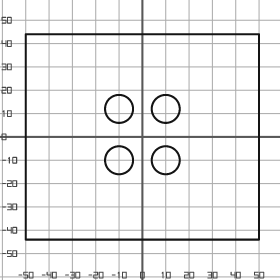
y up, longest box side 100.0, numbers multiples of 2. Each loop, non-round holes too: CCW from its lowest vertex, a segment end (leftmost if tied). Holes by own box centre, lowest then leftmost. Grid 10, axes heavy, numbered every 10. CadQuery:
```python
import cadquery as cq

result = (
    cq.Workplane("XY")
    .moveTo(-50.0, -44.0)
    .lineTo(50.0, -44.0)
    .lineTo(50.0, 44.0)
    .lineTo(-50.0, 44.0)
    .close()
    .moveTo(-10.0, -10.0)
    .circle(6.0)
    .moveTo(10.0, -10.0)
    .circle(6.0)
    .moveTo(-10.0, 12.0)
    .circle(6.0)
    .moveTo(10.0, 12.0)
    .circle(6.0)
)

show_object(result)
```